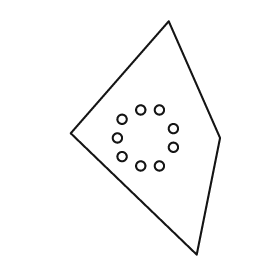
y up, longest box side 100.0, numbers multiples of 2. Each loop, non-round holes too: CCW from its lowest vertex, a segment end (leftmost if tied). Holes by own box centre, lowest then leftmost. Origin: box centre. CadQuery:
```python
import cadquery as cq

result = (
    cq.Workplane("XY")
    .moveTo(22.0, -50.0)
    .lineTo(32.0, 0.0)
    .lineTo(10.0, 50.0)
    .lineTo(-32.0, 2.0)
    .close()
    .moveTo(-2.0, -12.0)
    .circle(2.0)
    .moveTo(6.0, -12.0)
    .circle(2.0)
    .moveTo(-10.0, -8.0)
    .circle(2.0)
    .moveTo(12.0, -4.0)
    .circle(2.0)
    .moveTo(-12.0, 0.0)
    .circle(2.0)
    .moveTo(12.0, 4.0)
    .circle(2.0)
    .moveTo(-10.0, 8.0)
    .circle(2.0)
    .moveTo(-2.0, 12.0)
    .circle(2.0)
    .moveTo(6.0, 12.0)
    .circle(2.0)
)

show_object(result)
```